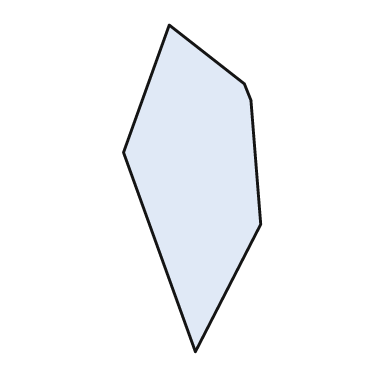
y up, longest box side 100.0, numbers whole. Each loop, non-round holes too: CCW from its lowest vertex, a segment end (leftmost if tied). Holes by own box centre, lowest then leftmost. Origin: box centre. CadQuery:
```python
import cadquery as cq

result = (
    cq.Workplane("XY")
    .moveTo(1.0, -50.0)
    .lineTo(21.0, -11.0)
    .lineTo(18.0, 27.0)
    .lineTo(16.0, 32.0)
    .lineTo(-7.0, 50.0)
    .lineTo(-21.0, 11.0)
    .close()
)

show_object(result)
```